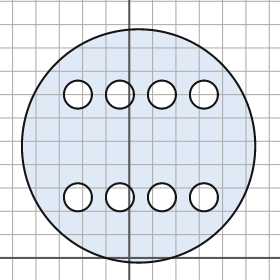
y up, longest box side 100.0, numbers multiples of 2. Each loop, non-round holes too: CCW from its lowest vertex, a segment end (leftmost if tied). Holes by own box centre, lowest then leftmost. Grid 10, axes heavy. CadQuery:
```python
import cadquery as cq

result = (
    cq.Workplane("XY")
    .moveTo(4.0, 48.0)
    .circle(50.0)
    .moveTo(-22.0, 26.0)
    .circle(6.0)
    .moveTo(-4.0, 26.0)
    .circle(6.0)
    .moveTo(14.0, 26.0)
    .circle(6.0)
    .moveTo(32.0, 26.0)
    .circle(6.0)
    .moveTo(-22.0, 70.0)
    .circle(6.0)
    .moveTo(-4.0, 70.0)
    .circle(6.0)
    .moveTo(14.0, 70.0)
    .circle(6.0)
    .moveTo(32.0, 70.0)
    .circle(6.0)
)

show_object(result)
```